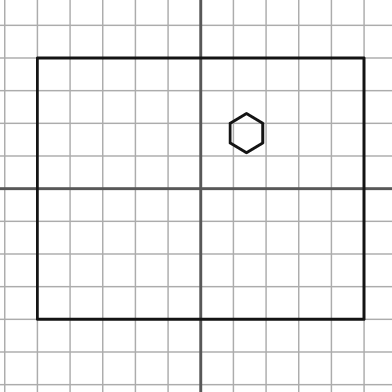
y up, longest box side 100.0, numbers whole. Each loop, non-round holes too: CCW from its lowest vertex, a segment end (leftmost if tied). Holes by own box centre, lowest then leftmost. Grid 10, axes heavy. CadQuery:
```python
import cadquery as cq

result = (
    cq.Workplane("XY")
    .moveTo(-50.0, -40.0)
    .lineTo(50.0, -40.0)
    .lineTo(50.0, 40.0)
    .lineTo(-50.0, 40.0)
    .close()
    .moveTo(14.0, 11.0)
    .lineTo(19.0, 14.0)
    .lineTo(19.0, 20.0)
    .lineTo(14.0, 23.0)
    .lineTo(9.0, 20.0)
    .lineTo(9.0, 14.0)
    .close()
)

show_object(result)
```